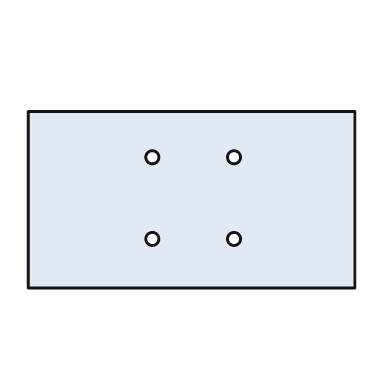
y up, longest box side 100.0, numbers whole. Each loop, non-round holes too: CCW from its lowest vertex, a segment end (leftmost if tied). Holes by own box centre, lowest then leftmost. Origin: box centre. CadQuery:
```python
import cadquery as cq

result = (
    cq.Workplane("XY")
    .moveTo(-50.0, -27.0)
    .lineTo(50.0, -27.0)
    .lineTo(50.0, 27.0)
    .lineTo(-50.0, 27.0)
    .close()
    .moveTo(-12.0, -12.0)
    .circle(2.0)
    .moveTo(13.0, -12.0)
    .circle(2.0)
    .moveTo(-12.0, 13.0)
    .circle(2.0)
    .moveTo(13.0, 13.0)
    .circle(2.0)
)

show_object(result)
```